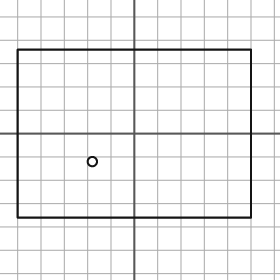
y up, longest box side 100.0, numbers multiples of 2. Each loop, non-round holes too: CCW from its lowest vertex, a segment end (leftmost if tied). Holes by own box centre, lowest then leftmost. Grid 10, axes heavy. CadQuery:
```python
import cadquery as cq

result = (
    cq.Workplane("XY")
    .moveTo(-50.0, -36.0)
    .lineTo(50.0, -36.0)
    .lineTo(50.0, 36.0)
    .lineTo(-50.0, 36.0)
    .close()
    .moveTo(-18.0, -12.0)
    .circle(2.0)
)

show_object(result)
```